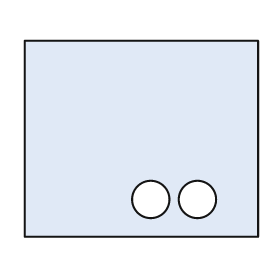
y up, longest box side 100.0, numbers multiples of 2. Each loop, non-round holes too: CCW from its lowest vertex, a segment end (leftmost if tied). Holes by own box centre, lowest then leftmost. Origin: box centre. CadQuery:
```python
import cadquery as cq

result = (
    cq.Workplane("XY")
    .moveTo(-50.0, -42.0)
    .lineTo(50.0, -42.0)
    .lineTo(50.0, 42.0)
    .lineTo(-50.0, 42.0)
    .close()
    .moveTo(4.0, -26.0)
    .circle(8.0)
    .moveTo(24.0, -26.0)
    .circle(8.0)
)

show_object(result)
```